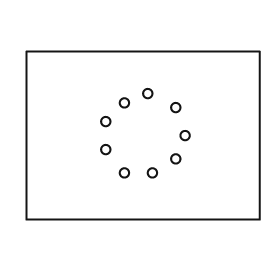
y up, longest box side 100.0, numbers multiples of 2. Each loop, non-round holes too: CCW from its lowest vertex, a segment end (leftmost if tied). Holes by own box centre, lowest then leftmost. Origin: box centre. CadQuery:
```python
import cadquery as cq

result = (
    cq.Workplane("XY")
    .moveTo(-50.0, -36.0)
    .lineTo(50.0, -36.0)
    .lineTo(50.0, 36.0)
    .lineTo(-50.0, 36.0)
    .close()
    .moveTo(-8.0, -16.0)
    .circle(2.0)
    .moveTo(4.0, -16.0)
    .circle(2.0)
    .moveTo(14.0, -10.0)
    .circle(2.0)
    .moveTo(-16.0, -6.0)
    .circle(2.0)
    .moveTo(18.0, 0.0)
    .circle(2.0)
    .moveTo(-16.0, 6.0)
    .circle(2.0)
    .moveTo(14.0, 12.0)
    .circle(2.0)
    .moveTo(-8.0, 14.0)
    .circle(2.0)
    .moveTo(2.0, 18.0)
    .circle(2.0)
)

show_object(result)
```